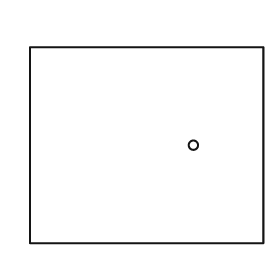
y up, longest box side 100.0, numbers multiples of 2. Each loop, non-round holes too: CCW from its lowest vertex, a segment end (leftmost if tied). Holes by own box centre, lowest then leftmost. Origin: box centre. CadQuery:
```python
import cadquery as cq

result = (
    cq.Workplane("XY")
    .moveTo(-50.0, -42.0)
    .lineTo(50.0, -42.0)
    .lineTo(50.0, 42.0)
    .lineTo(-50.0, 42.0)
    .close()
    .moveTo(20.0, 0.0)
    .circle(2.0)
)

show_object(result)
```